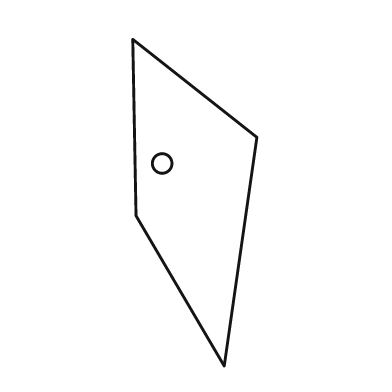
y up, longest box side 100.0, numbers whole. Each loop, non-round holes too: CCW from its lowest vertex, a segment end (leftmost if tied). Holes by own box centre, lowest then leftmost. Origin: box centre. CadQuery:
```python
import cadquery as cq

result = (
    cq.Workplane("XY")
    .moveTo(9.0, -50.0)
    .lineTo(19.0, 20.0)
    .lineTo(-19.0, 50.0)
    .lineTo(-18.0, -4.0)
    .close()
    .moveTo(-10.0, 12.0)
    .circle(3.0)
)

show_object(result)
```